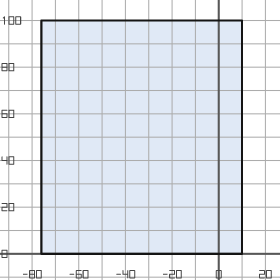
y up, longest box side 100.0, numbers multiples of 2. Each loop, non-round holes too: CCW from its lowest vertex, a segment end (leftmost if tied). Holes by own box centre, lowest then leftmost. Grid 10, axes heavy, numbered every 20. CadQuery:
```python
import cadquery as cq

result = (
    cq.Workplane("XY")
    .moveTo(-76.0, 0.0)
    .lineTo(10.0, 0.0)
    .lineTo(10.0, 100.0)
    .lineTo(-76.0, 100.0)
    .close()
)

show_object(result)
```